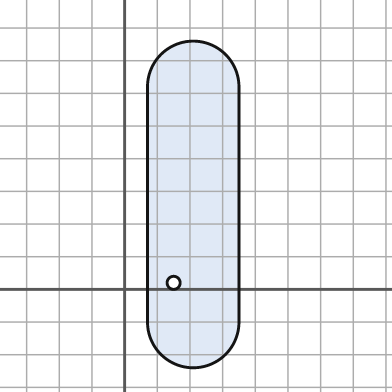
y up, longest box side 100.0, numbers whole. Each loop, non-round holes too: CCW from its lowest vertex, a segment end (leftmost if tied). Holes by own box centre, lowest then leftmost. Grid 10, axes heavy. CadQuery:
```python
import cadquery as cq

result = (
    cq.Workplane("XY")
    .moveTo(7.0, -10.0)
    .threePointArc((21.0, -24.0), (35.0, -10.0))
    .lineTo(35.0, 62.0)
    .threePointArc((21.0, 76.0), (7.0, 62.0))
    .close()
    .moveTo(15.0, 2.0)
    .circle(2.0)
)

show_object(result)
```